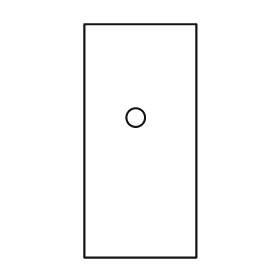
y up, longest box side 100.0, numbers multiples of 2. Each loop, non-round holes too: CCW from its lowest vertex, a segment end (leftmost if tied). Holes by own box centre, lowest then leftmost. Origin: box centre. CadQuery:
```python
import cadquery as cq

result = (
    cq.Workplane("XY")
    .moveTo(-24.0, -50.0)
    .lineTo(24.0, -50.0)
    .lineTo(24.0, 50.0)
    .lineTo(-24.0, 50.0)
    .close()
    .moveTo(-2.0, 10.0)
    .circle(4.0)
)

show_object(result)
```